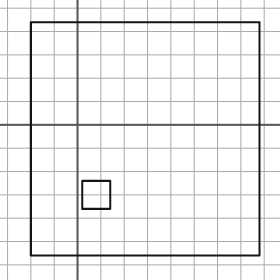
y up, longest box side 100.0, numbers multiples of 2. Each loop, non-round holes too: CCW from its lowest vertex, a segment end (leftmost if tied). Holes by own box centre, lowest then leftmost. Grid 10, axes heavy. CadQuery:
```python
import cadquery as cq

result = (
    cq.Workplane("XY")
    .moveTo(-20.0, -56.0)
    .lineTo(78.0, -56.0)
    .lineTo(78.0, 44.0)
    .lineTo(-20.0, 44.0)
    .close()
    .moveTo(2.0, -36.0)
    .lineTo(14.0, -36.0)
    .lineTo(14.0, -24.0)
    .lineTo(2.0, -24.0)
    .close()
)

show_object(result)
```